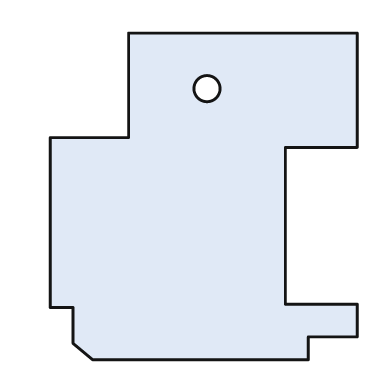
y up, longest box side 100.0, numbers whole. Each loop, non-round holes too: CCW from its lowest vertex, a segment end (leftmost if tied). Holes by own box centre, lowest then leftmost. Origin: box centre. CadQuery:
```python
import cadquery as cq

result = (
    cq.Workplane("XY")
    .moveTo(-34.0, -50.0)
    .lineTo(32.0, -50.0)
    .lineTo(32.0, -43.0)
    .lineTo(47.0, -43.0)
    .lineTo(47.0, -33.0)
    .lineTo(25.0, -33.0)
    .lineTo(25.0, 15.0)
    .lineTo(47.0, 15.0)
    .lineTo(47.0, 50.0)
    .lineTo(-23.0, 50.0)
    .lineTo(-23.0, 18.0)
    .lineTo(-47.0, 18.0)
    .lineTo(-47.0, -34.0)
    .lineTo(-40.0, -34.0)
    .lineTo(-40.0, -45.0)
    .close()
    .moveTo(1.0, 33.0)
    .circle(4.0)
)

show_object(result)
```